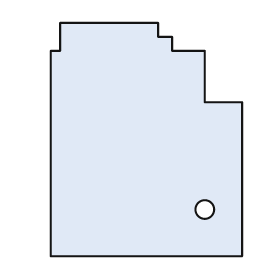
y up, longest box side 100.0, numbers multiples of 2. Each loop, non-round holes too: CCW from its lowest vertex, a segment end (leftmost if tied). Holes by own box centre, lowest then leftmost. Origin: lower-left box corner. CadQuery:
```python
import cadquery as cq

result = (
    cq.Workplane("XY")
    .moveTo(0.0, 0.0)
    .lineTo(82.0, 0.0)
    .lineTo(82.0, 66.0)
    .lineTo(66.0, 66.0)
    .lineTo(66.0, 88.0)
    .lineTo(52.0, 88.0)
    .lineTo(52.0, 94.0)
    .lineTo(46.0, 94.0)
    .lineTo(46.0, 100.0)
    .lineTo(4.0, 100.0)
    .lineTo(4.0, 88.0)
    .lineTo(0.0, 88.0)
    .close()
    .moveTo(66.0, 20.0)
    .circle(4.0)
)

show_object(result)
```